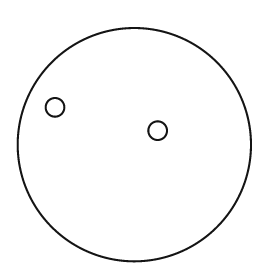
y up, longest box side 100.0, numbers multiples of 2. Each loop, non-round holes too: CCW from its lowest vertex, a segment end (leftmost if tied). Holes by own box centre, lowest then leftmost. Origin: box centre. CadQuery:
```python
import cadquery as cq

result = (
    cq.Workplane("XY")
    .moveTo(0.0, 0.0)
    .circle(50.0)
    .moveTo(10.0, 6.0)
    .circle(4.0)
    .moveTo(-34.0, 16.0)
    .circle(4.0)
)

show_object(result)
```